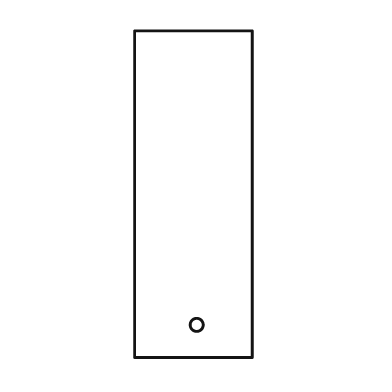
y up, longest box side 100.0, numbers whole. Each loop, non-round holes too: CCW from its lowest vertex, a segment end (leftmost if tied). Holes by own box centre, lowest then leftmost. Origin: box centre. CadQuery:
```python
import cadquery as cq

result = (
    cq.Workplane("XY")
    .moveTo(-18.0, -50.0)
    .lineTo(18.0, -50.0)
    .lineTo(18.0, 50.0)
    .lineTo(-18.0, 50.0)
    .close()
    .moveTo(1.0, -40.0)
    .circle(2.0)
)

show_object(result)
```